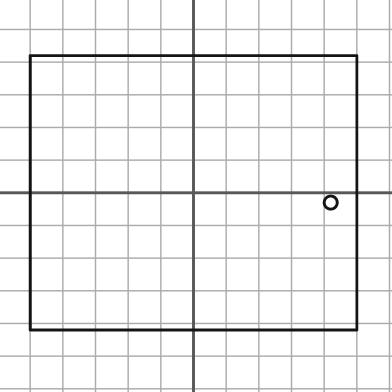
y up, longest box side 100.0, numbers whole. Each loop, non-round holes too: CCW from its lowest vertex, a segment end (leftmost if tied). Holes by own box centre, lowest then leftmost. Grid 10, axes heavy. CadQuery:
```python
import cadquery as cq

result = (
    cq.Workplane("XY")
    .moveTo(-50.0, -42.0)
    .lineTo(50.0, -42.0)
    .lineTo(50.0, 42.0)
    .lineTo(-50.0, 42.0)
    .close()
    .moveTo(42.0, -3.0)
    .circle(2.0)
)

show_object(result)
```